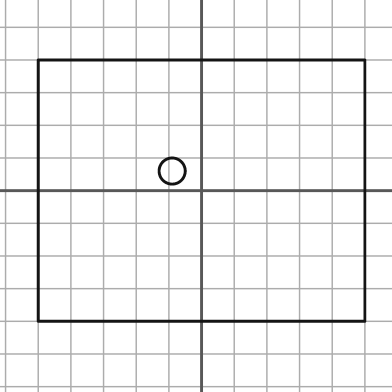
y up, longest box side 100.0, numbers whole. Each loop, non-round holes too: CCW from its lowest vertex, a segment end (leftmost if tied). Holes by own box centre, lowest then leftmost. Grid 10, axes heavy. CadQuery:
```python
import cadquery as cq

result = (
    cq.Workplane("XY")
    .moveTo(-50.0, -40.0)
    .lineTo(50.0, -40.0)
    .lineTo(50.0, 40.0)
    .lineTo(-50.0, 40.0)
    .close()
    .moveTo(-9.0, 6.0)
    .circle(4.0)
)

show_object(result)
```